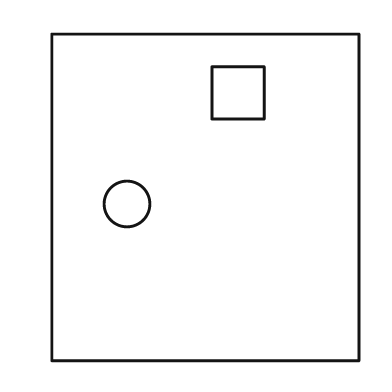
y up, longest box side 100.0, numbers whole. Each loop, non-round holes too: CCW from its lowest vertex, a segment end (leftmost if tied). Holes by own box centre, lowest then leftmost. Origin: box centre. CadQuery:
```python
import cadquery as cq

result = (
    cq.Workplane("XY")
    .moveTo(-47.0, -50.0)
    .lineTo(47.0, -50.0)
    .lineTo(47.0, 50.0)
    .lineTo(-47.0, 50.0)
    .close()
    .moveTo(-24.0, -2.0)
    .circle(7.0)
    .moveTo(2.0, 24.0)
    .lineTo(18.0, 24.0)
    .lineTo(18.0, 40.0)
    .lineTo(2.0, 40.0)
    .close()
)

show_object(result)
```